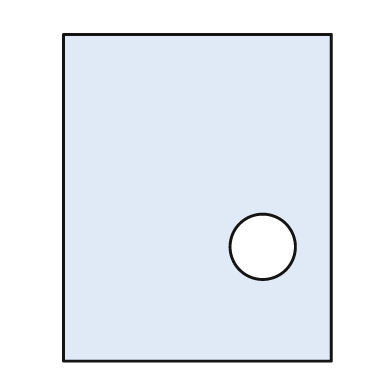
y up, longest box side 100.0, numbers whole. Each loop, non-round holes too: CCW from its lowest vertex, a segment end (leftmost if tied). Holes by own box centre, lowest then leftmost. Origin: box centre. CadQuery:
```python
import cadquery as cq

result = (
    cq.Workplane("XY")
    .moveTo(-41.0, -50.0)
    .lineTo(41.0, -50.0)
    .lineTo(41.0, 50.0)
    .lineTo(-41.0, 50.0)
    .close()
    .moveTo(20.0, -15.0)
    .circle(10.0)
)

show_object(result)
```